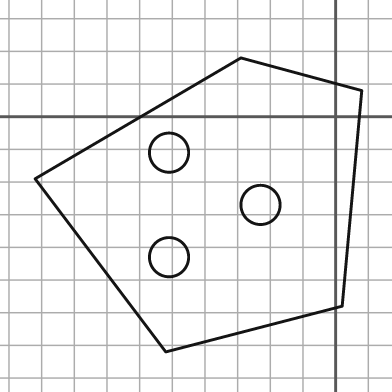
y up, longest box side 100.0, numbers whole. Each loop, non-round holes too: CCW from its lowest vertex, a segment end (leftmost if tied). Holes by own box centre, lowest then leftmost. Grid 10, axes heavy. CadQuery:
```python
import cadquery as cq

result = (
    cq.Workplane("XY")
    .moveTo(-52.0, -72.0)
    .lineTo(2.0, -58.0)
    .lineTo(8.0, 8.0)
    .lineTo(-29.0, 18.0)
    .lineTo(-92.0, -19.0)
    .close()
    .moveTo(-51.0, -43.0)
    .circle(6.0)
    .moveTo(-23.0, -27.0)
    .circle(6.0)
    .moveTo(-51.0, -11.0)
    .circle(6.0)
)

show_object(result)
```